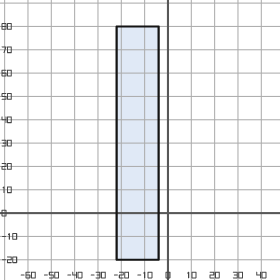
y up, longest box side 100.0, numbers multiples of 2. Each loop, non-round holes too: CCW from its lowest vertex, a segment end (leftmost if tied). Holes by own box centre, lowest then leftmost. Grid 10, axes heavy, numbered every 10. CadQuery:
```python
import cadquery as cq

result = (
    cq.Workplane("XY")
    .moveTo(-22.0, -20.0)
    .lineTo(-4.0, -20.0)
    .lineTo(-4.0, 80.0)
    .lineTo(-22.0, 80.0)
    .close()
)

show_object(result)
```